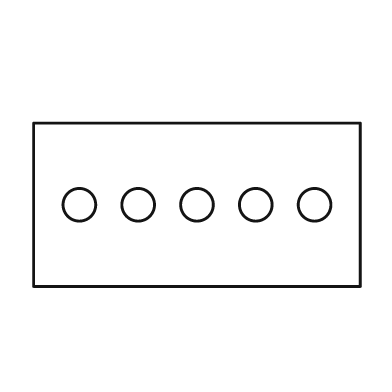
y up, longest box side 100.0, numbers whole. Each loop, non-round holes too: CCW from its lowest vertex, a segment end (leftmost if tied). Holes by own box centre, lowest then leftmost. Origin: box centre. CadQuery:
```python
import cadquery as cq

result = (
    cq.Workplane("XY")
    .moveTo(-50.0, -25.0)
    .lineTo(50.0, -25.0)
    .lineTo(50.0, 25.0)
    .lineTo(-50.0, 25.0)
    .close()
    .moveTo(-36.0, 0.0)
    .circle(5.0)
    .moveTo(-18.0, 0.0)
    .circle(5.0)
    .moveTo(0.0, 0.0)
    .circle(5.0)
    .moveTo(18.0, 0.0)
    .circle(5.0)
    .moveTo(36.0, 0.0)
    .circle(5.0)
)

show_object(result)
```